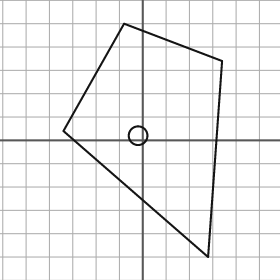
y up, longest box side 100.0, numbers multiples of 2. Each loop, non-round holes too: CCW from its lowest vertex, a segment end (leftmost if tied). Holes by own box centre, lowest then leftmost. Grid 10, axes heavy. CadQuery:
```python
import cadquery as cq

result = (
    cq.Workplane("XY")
    .moveTo(28.0, -50.0)
    .lineTo(34.0, 34.0)
    .lineTo(-8.0, 50.0)
    .lineTo(-34.0, 4.0)
    .close()
    .moveTo(-2.0, 2.0)
    .circle(4.0)
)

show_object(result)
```